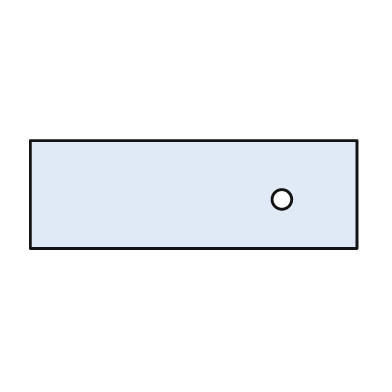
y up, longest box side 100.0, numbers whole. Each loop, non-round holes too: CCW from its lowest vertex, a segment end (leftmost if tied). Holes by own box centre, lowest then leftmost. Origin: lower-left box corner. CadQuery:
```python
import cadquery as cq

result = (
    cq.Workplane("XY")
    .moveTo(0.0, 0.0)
    .lineTo(100.0, 0.0)
    .lineTo(100.0, 33.0)
    .lineTo(0.0, 33.0)
    .close()
    .moveTo(77.0, 15.0)
    .circle(3.0)
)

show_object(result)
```